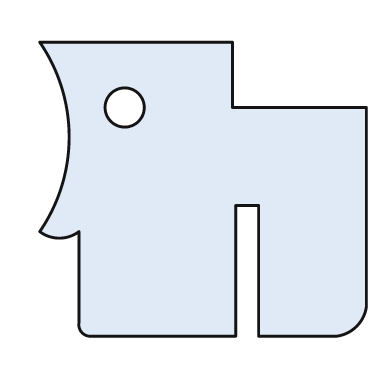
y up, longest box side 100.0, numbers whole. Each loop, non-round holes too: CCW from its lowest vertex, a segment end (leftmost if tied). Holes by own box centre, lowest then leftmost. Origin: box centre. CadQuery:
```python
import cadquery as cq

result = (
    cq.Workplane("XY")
    .moveTo(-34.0, -45.0)
    .lineTo(10.0, -45.0)
    .lineTo(10.0, -5.0)
    .lineTo(17.0, -5.0)
    .lineTo(17.0, -45.0)
    .lineTo(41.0, -45.0)
    .threePointArc((47.0, -42.0), (50.0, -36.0))
    .lineTo(50.0, 25.0)
    .lineTo(9.0, 25.0)
    .lineTo(9.0, 45.0)
    .lineTo(-50.0, 45.0)
    .threePointArc((-41.0, 16.0), (-50.0, -13.0))
    .threePointArc((-44.0, -15.0), (-38.0, -13.0))
    .lineTo(-38.0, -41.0)
    .threePointArc((-37.0, -44.0), (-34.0, -45.0))
    .close()
    .moveTo(-24.0, 25.0)
    .circle(6.0)
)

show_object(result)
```